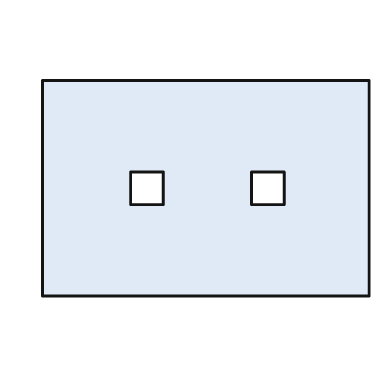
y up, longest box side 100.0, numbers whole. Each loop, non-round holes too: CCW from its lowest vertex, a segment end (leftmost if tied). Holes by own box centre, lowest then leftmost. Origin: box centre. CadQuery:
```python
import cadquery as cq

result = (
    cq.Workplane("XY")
    .moveTo(-50.0, -33.0)
    .lineTo(50.0, -33.0)
    .lineTo(50.0, 33.0)
    .lineTo(-50.0, 33.0)
    .close()
    .moveTo(-23.0, -5.0)
    .lineTo(-13.0, -5.0)
    .lineTo(-13.0, 5.0)
    .lineTo(-23.0, 5.0)
    .close()
    .moveTo(14.0, -5.0)
    .lineTo(24.0, -5.0)
    .lineTo(24.0, 5.0)
    .lineTo(14.0, 5.0)
    .close()
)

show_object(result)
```